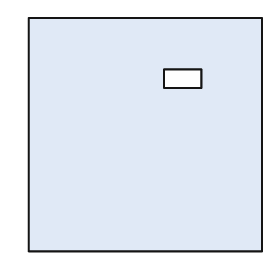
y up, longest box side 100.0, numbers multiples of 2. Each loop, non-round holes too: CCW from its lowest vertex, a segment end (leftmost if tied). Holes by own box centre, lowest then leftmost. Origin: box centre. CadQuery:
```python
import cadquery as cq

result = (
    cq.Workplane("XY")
    .moveTo(-50.0, -50.0)
    .lineTo(50.0, -50.0)
    .lineTo(50.0, 50.0)
    .lineTo(-50.0, 50.0)
    .close()
    .moveTo(8.0, 20.0)
    .lineTo(24.0, 20.0)
    .lineTo(24.0, 28.0)
    .lineTo(8.0, 28.0)
    .close()
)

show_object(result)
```